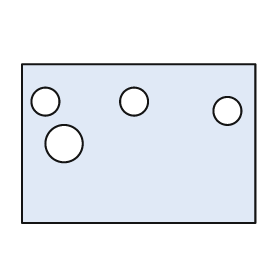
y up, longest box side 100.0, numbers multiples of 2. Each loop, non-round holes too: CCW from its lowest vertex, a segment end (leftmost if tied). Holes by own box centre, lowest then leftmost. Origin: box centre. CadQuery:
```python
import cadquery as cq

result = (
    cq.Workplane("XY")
    .moveTo(-50.0, -34.0)
    .lineTo(50.0, -34.0)
    .lineTo(50.0, 34.0)
    .lineTo(-50.0, 34.0)
    .close()
    .moveTo(-32.0, 0.0)
    .circle(8.0)
    .moveTo(38.0, 14.0)
    .circle(6.0)
    .moveTo(-40.0, 18.0)
    .circle(6.0)
    .moveTo(-2.0, 18.0)
    .circle(6.0)
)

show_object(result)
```